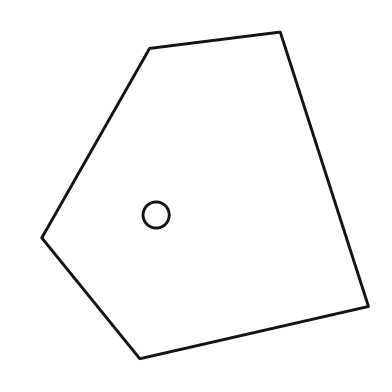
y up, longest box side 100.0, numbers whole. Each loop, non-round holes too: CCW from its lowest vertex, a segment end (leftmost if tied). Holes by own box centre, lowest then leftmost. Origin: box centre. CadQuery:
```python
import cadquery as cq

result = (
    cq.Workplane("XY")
    .moveTo(-20.0, -50.0)
    .lineTo(50.0, -34.0)
    .lineTo(23.0, 50.0)
    .lineTo(-17.0, 45.0)
    .lineTo(-50.0, -13.0)
    .close()
    .moveTo(-15.0, -6.0)
    .circle(4.0)
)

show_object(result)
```